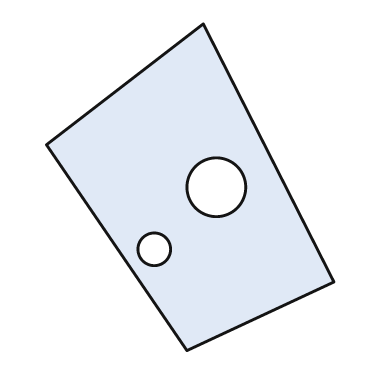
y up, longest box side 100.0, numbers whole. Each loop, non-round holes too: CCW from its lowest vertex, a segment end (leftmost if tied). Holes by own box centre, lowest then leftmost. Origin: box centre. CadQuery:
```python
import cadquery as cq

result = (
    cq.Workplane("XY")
    .moveTo(-1.0, -50.0)
    .lineTo(44.0, -29.0)
    .lineTo(4.0, 50.0)
    .lineTo(-44.0, 13.0)
    .close()
    .moveTo(-11.0, -19.0)
    .circle(5.0)
    .moveTo(8.0, 0.0)
    .circle(9.0)
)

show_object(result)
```